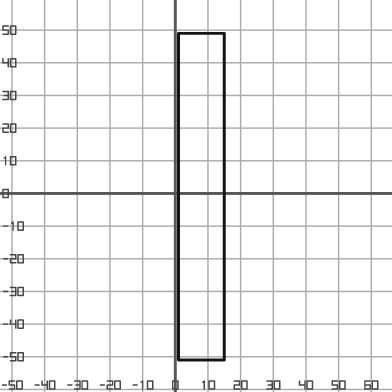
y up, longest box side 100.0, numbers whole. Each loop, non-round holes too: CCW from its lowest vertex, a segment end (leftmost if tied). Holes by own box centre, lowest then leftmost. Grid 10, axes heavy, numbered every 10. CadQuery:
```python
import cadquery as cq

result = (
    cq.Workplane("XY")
    .moveTo(1.0, -51.0)
    .lineTo(15.0, -51.0)
    .lineTo(15.0, 49.0)
    .lineTo(1.0, 49.0)
    .close()
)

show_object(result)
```